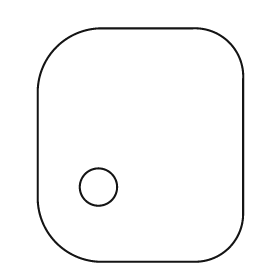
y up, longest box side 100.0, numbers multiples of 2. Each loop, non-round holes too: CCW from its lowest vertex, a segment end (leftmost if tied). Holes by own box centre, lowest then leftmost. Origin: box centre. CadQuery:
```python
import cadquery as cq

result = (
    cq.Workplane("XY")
    .moveTo(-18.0, -50.0)
    .lineTo(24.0, -50.0)
    .threePointArc((38.0, -44.0), (44.0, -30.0))
    .lineTo(44.0, 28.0)
    .threePointArc((38.0, 44.0), (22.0, 50.0))
    .lineTo(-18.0, 50.0)
    .threePointArc((-36.0, 42.0), (-44.0, 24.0))
    .lineTo(-44.0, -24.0)
    .threePointArc((-36.0, -42.0), (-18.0, -50.0))
    .close()
    .moveTo(-18.0, -18.0)
    .circle(8.0)
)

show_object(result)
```